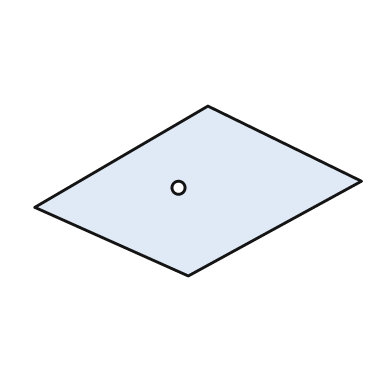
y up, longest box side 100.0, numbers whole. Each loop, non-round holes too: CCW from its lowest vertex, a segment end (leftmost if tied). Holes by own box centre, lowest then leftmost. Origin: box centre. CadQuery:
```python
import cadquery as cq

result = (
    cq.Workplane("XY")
    .moveTo(-3.0, -26.0)
    .lineTo(50.0, 3.0)
    .lineTo(3.0, 26.0)
    .lineTo(-50.0, -5.0)
    .close()
    .moveTo(-6.0, 1.0)
    .circle(2.0)
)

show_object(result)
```